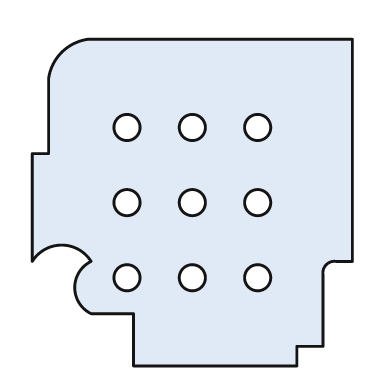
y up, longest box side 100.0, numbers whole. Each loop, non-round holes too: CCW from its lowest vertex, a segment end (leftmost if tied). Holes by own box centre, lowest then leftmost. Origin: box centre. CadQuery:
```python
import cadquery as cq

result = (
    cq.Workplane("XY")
    .moveTo(-18.0, -50.0)
    .lineTo(32.0, -50.0)
    .lineTo(32.0, -44.0)
    .lineTo(40.0, -44.0)
    .lineTo(40.0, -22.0)
    .threePointArc((41.0, -19.0), (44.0, -18.0))
    .lineTo(49.0, -18.0)
    .lineTo(49.0, 50.0)
    .lineTo(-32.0, 50.0)
    .threePointArc((-40.0, 46.0), (-44.0, 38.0))
    .lineTo(-44.0, 15.0)
    .lineTo(-49.0, 15.0)
    .lineTo(-49.0, -18.0)
    .threePointArc((-40.0, -13.0), (-31.0, -18.0))
    .threePointArc((-36.0, -26.0), (-31.0, -34.0))
    .lineTo(-18.0, -34.0)
    .close()
    .moveTo(-20.0, -23.0)
    .circle(4.0)
    .moveTo(0.0, -23.0)
    .circle(4.0)
    .moveTo(20.0, -23.0)
    .circle(4.0)
    .moveTo(-20.0, 0.0)
    .circle(4.0)
    .moveTo(0.0, 0.0)
    .circle(4.0)
    .moveTo(20.0, 0.0)
    .circle(4.0)
    .moveTo(-20.0, 23.0)
    .circle(4.0)
    .moveTo(0.0, 23.0)
    .circle(4.0)
    .moveTo(20.0, 23.0)
    .circle(4.0)
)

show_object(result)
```